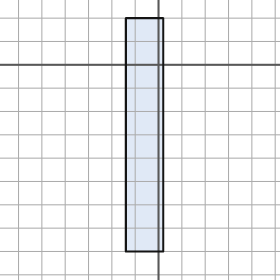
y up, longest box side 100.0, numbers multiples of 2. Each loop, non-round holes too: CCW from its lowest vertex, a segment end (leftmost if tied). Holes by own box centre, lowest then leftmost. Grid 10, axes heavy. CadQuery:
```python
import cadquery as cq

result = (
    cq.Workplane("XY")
    .moveTo(-14.0, -80.0)
    .lineTo(2.0, -80.0)
    .lineTo(2.0, 20.0)
    .lineTo(-14.0, 20.0)
    .close()
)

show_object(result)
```